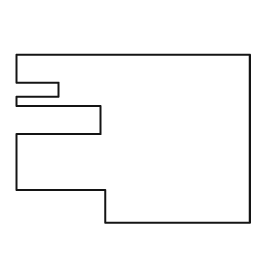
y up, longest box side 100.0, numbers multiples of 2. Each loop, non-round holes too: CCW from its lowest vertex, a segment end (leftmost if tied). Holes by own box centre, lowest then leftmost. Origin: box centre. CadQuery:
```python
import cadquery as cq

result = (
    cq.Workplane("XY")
    .moveTo(-12.0, -36.0)
    .lineTo(50.0, -36.0)
    .lineTo(50.0, 36.0)
    .lineTo(-50.0, 36.0)
    .lineTo(-50.0, 24.0)
    .lineTo(-32.0, 24.0)
    .lineTo(-32.0, 18.0)
    .lineTo(-50.0, 18.0)
    .lineTo(-50.0, 14.0)
    .lineTo(-14.0, 14.0)
    .lineTo(-14.0, 2.0)
    .lineTo(-50.0, 2.0)
    .lineTo(-50.0, -22.0)
    .lineTo(-12.0, -22.0)
    .close()
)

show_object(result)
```